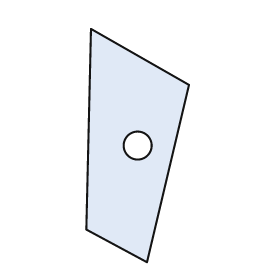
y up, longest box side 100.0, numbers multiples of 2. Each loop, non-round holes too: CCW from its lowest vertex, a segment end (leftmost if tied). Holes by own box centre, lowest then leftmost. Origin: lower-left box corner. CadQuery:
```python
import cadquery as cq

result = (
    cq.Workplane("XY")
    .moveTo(26.0, 0.0)
    .lineTo(44.0, 76.0)
    .lineTo(2.0, 100.0)
    .lineTo(0.0, 14.0)
    .close()
    .moveTo(22.0, 50.0)
    .circle(6.0)
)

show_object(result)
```